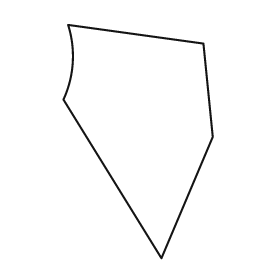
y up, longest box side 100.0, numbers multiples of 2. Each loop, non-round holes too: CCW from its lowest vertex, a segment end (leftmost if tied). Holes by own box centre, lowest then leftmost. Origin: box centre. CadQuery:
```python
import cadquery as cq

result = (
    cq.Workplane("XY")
    .moveTo(10.0, -50.0)
    .lineTo(32.0, 2.0)
    .lineTo(28.0, 42.0)
    .lineTo(-30.0, 50.0)
    .threePointArc((-28.0, 34.0), (-32.0, 18.0))
    .close()
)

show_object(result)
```